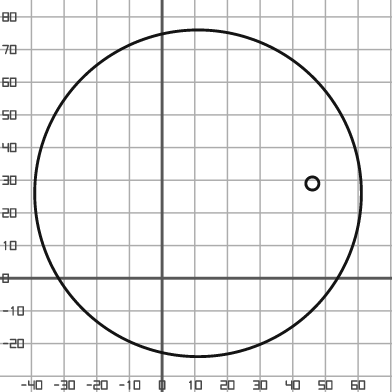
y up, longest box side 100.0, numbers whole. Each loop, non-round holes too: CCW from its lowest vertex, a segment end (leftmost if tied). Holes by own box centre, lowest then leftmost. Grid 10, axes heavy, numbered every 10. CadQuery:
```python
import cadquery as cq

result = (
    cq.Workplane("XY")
    .moveTo(11.0, 26.0)
    .circle(50.0)
    .moveTo(46.0, 29.0)
    .circle(2.0)
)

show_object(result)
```